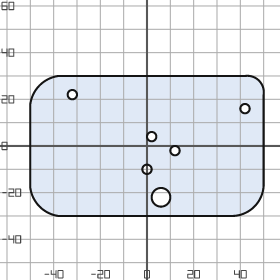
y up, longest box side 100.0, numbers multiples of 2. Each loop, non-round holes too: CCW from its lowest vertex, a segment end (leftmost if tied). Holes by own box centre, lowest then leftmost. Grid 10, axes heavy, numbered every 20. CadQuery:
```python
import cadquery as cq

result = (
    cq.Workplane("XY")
    .moveTo(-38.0, -30.0)
    .lineTo(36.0, -30.0)
    .threePointArc((46.0, -26.0), (50.0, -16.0))
    .lineTo(50.0, 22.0)
    .threePointArc((48.0, 28.0), (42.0, 30.0))
    .lineTo(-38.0, 30.0)
    .threePointArc((-46.0, 26.0), (-50.0, 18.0))
    .lineTo(-50.0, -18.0)
    .threePointArc((-46.0, -26.0), (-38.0, -30.0))
    .close()
    .moveTo(6.0, -22.0)
    .circle(4.0)
    .moveTo(0.0, -10.0)
    .circle(2.0)
    .moveTo(12.0, -2.0)
    .circle(2.0)
    .moveTo(2.0, 4.0)
    .circle(2.0)
    .moveTo(42.0, 16.0)
    .circle(2.0)
    .moveTo(-32.0, 22.0)
    .circle(2.0)
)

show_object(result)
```